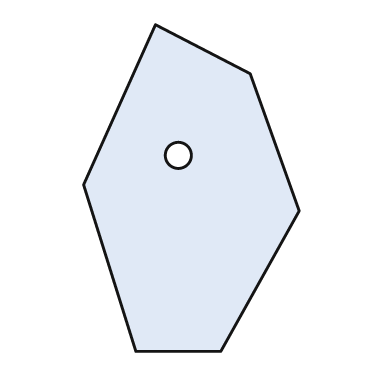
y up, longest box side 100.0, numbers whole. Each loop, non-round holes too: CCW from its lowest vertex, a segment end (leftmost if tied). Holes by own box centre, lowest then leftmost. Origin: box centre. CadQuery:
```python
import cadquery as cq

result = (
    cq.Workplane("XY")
    .moveTo(-17.0, -50.0)
    .lineTo(9.0, -50.0)
    .lineTo(33.0, -7.0)
    .lineTo(18.0, 35.0)
    .lineTo(-11.0, 50.0)
    .lineTo(-33.0, 1.0)
    .close()
    .moveTo(-4.0, 10.0)
    .circle(4.0)
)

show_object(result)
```